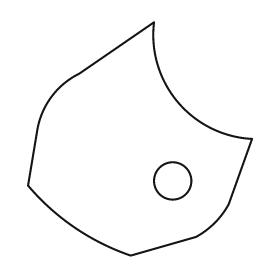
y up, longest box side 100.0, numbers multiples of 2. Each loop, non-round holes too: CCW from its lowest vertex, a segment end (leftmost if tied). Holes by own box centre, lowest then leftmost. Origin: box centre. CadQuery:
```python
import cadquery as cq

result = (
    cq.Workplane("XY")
    .moveTo(-4.0, -50.0)
    .lineTo(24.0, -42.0)
    .threePointArc((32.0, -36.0), (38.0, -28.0))
    .lineTo(48.0, 0.0)
    .threePointArc((16.0, 16.0), (6.0, 50.0))
    .lineTo(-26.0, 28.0)
    .threePointArc((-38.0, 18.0), (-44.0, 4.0))
    .lineTo(-48.0, -20.0)
    .threePointArc((-28.0, -38.0), (-4.0, -50.0))
    .close()
    .moveTo(14.0, -18.0)
    .circle(8.0)
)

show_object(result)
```